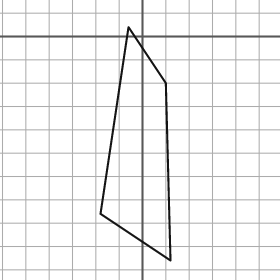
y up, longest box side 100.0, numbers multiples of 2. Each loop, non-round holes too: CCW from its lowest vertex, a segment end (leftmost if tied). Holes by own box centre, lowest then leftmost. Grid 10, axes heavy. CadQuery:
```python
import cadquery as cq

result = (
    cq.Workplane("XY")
    .moveTo(12.0, -96.0)
    .lineTo(10.0, -20.0)
    .lineTo(-6.0, 4.0)
    .lineTo(-18.0, -76.0)
    .close()
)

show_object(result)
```